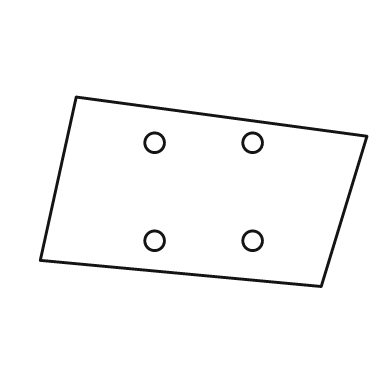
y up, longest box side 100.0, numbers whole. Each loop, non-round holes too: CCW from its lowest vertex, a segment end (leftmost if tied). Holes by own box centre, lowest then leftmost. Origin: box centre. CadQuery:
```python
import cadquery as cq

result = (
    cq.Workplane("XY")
    .moveTo(36.0, -29.0)
    .lineTo(50.0, 17.0)
    .lineTo(-39.0, 29.0)
    .lineTo(-50.0, -21.0)
    .close()
    .moveTo(-15.0, -15.0)
    .circle(3.0)
    .moveTo(15.0, -15.0)
    .circle(3.0)
    .moveTo(-15.0, 15.0)
    .circle(3.0)
    .moveTo(15.0, 15.0)
    .circle(3.0)
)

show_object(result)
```